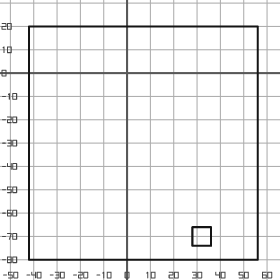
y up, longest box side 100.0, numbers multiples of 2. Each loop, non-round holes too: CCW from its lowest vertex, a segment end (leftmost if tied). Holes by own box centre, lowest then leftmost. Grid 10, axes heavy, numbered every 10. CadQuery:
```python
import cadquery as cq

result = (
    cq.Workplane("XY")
    .moveTo(-42.0, -80.0)
    .lineTo(56.0, -80.0)
    .lineTo(56.0, 20.0)
    .lineTo(-42.0, 20.0)
    .close()
    .moveTo(28.0, -74.0)
    .lineTo(36.0, -74.0)
    .lineTo(36.0, -66.0)
    .lineTo(28.0, -66.0)
    .close()
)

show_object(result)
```